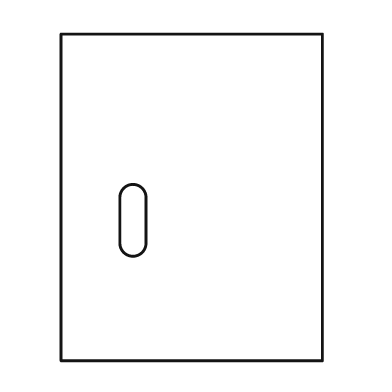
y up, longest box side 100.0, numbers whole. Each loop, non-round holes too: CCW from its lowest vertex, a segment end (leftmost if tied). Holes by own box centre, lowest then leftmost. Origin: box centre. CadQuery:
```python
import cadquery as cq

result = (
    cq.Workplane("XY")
    .moveTo(-40.0, -50.0)
    .lineTo(40.0, -50.0)
    .lineTo(40.0, 50.0)
    .lineTo(-40.0, 50.0)
    .close()
    .moveTo(-22.0, -14.0)
    .threePointArc((-18.0, -18.0), (-14.0, -14.0))
    .lineTo(-14.0, 0.0)
    .threePointArc((-18.0, 4.0), (-22.0, 0.0))
    .close()
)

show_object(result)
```